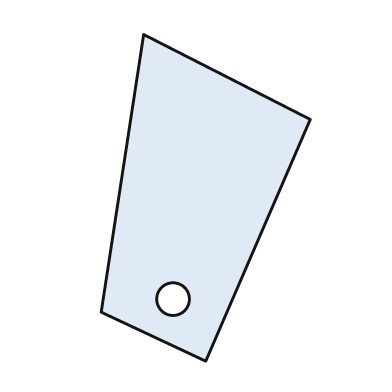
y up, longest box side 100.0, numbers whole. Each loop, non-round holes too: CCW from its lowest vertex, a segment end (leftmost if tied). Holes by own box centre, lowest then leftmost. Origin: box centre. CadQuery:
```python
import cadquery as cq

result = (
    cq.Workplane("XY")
    .moveTo(0.0, -50.0)
    .lineTo(32.0, 24.0)
    .lineTo(-19.0, 50.0)
    .lineTo(-32.0, -35.0)
    .close()
    .moveTo(-10.0, -31.0)
    .circle(5.0)
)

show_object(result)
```